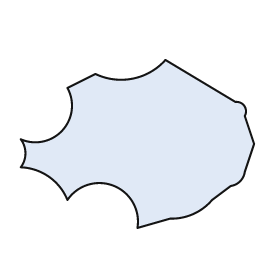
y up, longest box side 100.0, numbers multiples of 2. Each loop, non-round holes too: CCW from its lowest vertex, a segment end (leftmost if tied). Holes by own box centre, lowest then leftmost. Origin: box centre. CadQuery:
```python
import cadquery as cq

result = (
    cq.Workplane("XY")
    .moveTo(0.0, -36.0)
    .lineTo(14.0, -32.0)
    .threePointArc((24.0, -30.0), (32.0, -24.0))
    .lineTo(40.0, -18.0)
    .threePointArc((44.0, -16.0), (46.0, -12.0))
    .lineTo(50.0, 0.0)
    .lineTo(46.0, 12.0)
    .threePointArc((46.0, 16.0), (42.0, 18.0))
    .lineTo(12.0, 36.0)
    .threePointArc((-2.0, 28.0), (-18.0, 30.0))
    .lineTo(-30.0, 24.0)
    .threePointArc((-32.0, 6.0), (-50.0, 2.0))
    .threePointArc((-48.0, -4.0), (-50.0, -10.0))
    .threePointArc((-38.0, -14.0), (-30.0, -24.0))
    .threePointArc((-10.0, -18.0), (0.0, -36.0))
    .close()
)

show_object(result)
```